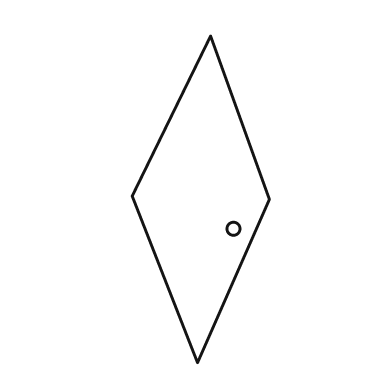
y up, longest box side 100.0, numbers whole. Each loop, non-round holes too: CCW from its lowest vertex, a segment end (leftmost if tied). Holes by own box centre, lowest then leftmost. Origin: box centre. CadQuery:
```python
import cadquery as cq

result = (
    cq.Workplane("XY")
    .moveTo(-1.0, -50.0)
    .lineTo(21.0, 0.0)
    .lineTo(3.0, 50.0)
    .lineTo(-21.0, 1.0)
    .close()
    .moveTo(10.0, -9.0)
    .circle(2.0)
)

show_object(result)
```